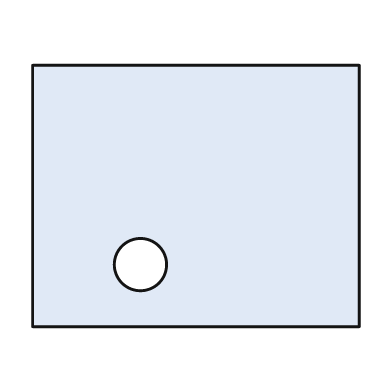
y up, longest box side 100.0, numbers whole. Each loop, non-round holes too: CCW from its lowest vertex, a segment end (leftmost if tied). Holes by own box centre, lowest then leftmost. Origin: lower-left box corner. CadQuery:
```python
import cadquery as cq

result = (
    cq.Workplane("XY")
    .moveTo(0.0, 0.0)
    .lineTo(100.0, 0.0)
    .lineTo(100.0, 80.0)
    .lineTo(0.0, 80.0)
    .close()
    .moveTo(33.0, 19.0)
    .circle(8.0)
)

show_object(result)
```